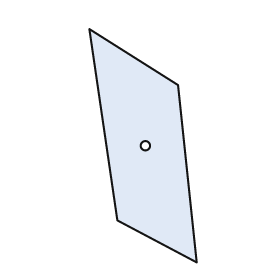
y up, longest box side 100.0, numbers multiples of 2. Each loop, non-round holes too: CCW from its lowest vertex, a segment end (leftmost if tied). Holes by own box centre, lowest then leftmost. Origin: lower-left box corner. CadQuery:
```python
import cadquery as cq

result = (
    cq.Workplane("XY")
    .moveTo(46.0, 0.0)
    .lineTo(38.0, 76.0)
    .lineTo(0.0, 100.0)
    .lineTo(12.0, 18.0)
    .close()
    .moveTo(24.0, 50.0)
    .circle(2.0)
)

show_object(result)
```